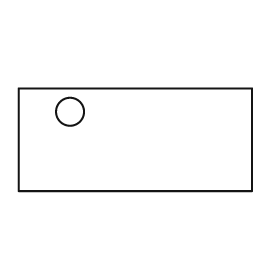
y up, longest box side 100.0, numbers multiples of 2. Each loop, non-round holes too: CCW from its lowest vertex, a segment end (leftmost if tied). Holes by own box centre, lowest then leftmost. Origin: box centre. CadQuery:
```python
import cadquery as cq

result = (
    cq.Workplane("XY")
    .moveTo(-50.0, -22.0)
    .lineTo(50.0, -22.0)
    .lineTo(50.0, 22.0)
    .lineTo(-50.0, 22.0)
    .close()
    .moveTo(-28.0, 12.0)
    .circle(6.0)
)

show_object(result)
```